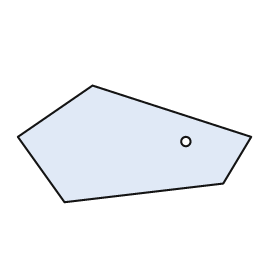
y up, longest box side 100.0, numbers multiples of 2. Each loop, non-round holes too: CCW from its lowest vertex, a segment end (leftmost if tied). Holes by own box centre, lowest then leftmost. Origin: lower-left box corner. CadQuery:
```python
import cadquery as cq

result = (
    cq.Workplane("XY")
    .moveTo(20.0, 0.0)
    .lineTo(88.0, 8.0)
    .lineTo(100.0, 28.0)
    .lineTo(32.0, 50.0)
    .lineTo(0.0, 28.0)
    .close()
    .moveTo(72.0, 26.0)
    .circle(2.0)
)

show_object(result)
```